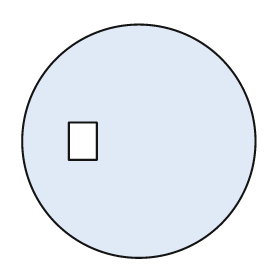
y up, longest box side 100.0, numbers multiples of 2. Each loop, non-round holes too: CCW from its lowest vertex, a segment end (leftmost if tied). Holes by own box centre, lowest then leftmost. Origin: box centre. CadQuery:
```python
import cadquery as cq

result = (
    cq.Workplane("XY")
    .moveTo(0.0, 0.0)
    .circle(50.0)
    .moveTo(-30.0, -8.0)
    .lineTo(-18.0, -8.0)
    .lineTo(-18.0, 8.0)
    .lineTo(-30.0, 8.0)
    .close()
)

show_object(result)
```